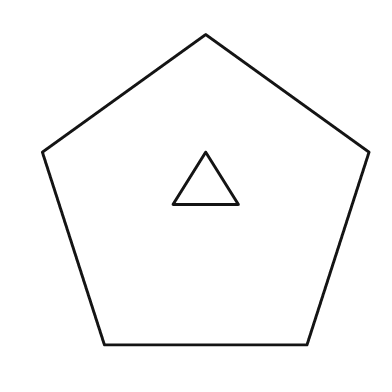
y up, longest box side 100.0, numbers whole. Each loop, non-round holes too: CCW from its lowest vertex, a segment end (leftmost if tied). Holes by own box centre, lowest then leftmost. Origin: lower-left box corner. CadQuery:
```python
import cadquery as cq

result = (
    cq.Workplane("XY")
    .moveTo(19.0, 0.0)
    .lineTo(81.0, 0.0)
    .lineTo(100.0, 59.0)
    .lineTo(50.0, 95.0)
    .lineTo(0.0, 59.0)
    .close()
    .moveTo(40.0, 43.0)
    .lineTo(60.0, 43.0)
    .lineTo(50.0, 59.0)
    .close()
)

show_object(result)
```